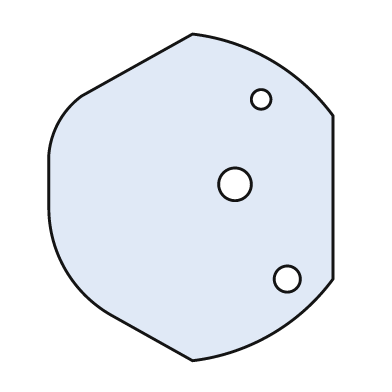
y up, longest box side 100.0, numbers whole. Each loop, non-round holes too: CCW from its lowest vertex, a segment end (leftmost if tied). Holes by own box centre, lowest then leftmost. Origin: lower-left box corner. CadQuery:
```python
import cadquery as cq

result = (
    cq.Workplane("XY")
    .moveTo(44.0, 0.0)
    .threePointArc((68.0, 8.0), (87.0, 25.0))
    .lineTo(87.0, 75.0)
    .threePointArc((68.0, 92.0), (44.0, 100.0))
    .lineTo(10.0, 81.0)
    .threePointArc((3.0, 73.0), (0.0, 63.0))
    .lineTo(0.0, 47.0)
    .threePointArc((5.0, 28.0), (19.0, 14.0))
    .close()
    .moveTo(73.0, 25.0)
    .circle(4.0)
    .moveTo(57.0, 54.0)
    .circle(5.0)
    .moveTo(65.0, 80.0)
    .circle(3.0)
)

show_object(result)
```